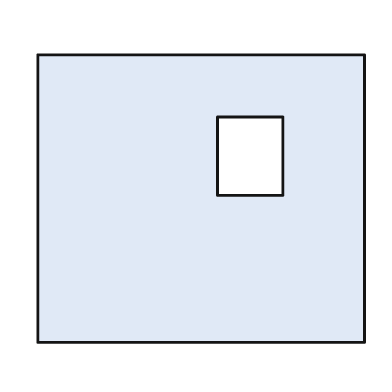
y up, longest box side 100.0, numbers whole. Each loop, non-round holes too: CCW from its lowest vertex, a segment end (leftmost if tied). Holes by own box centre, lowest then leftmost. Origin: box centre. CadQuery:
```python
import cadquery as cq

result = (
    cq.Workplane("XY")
    .moveTo(-50.0, -44.0)
    .lineTo(50.0, -44.0)
    .lineTo(50.0, 44.0)
    .lineTo(-50.0, 44.0)
    .close()
    .moveTo(5.0, 1.0)
    .lineTo(25.0, 1.0)
    .lineTo(25.0, 25.0)
    .lineTo(5.0, 25.0)
    .close()
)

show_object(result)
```